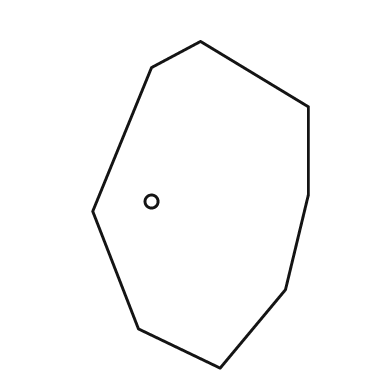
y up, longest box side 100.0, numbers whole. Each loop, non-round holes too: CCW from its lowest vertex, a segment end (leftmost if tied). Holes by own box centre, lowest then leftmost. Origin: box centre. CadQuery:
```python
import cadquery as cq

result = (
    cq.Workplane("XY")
    .moveTo(6.0, -50.0)
    .lineTo(26.0, -26.0)
    .lineTo(33.0, 3.0)
    .lineTo(33.0, 30.0)
    .lineTo(0.0, 50.0)
    .lineTo(-15.0, 42.0)
    .lineTo(-33.0, -2.0)
    .lineTo(-19.0, -38.0)
    .close()
    .moveTo(-15.0, 1.0)
    .circle(2.0)
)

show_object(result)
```